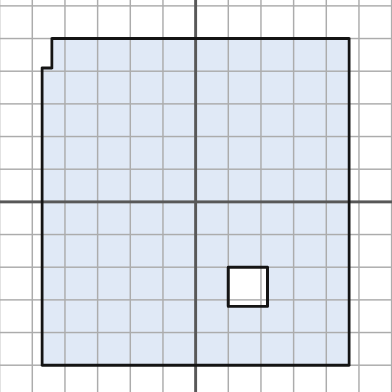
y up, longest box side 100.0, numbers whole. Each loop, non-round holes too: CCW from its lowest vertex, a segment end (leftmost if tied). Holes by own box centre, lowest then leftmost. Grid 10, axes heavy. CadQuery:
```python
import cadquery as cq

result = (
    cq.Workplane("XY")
    .moveTo(-47.0, -50.0)
    .lineTo(47.0, -50.0)
    .lineTo(47.0, 50.0)
    .lineTo(-44.0, 50.0)
    .lineTo(-44.0, 41.0)
    .lineTo(-47.0, 41.0)
    .close()
    .moveTo(10.0, -32.0)
    .lineTo(22.0, -32.0)
    .lineTo(22.0, -20.0)
    .lineTo(10.0, -20.0)
    .close()
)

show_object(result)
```